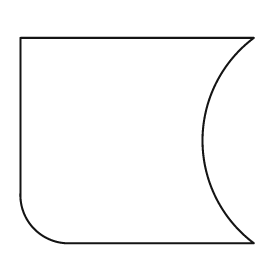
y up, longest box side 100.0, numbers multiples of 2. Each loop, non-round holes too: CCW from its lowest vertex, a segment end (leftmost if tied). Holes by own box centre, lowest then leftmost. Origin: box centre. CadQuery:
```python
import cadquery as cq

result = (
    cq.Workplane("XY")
    .moveTo(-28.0, -44.0)
    .lineTo(50.0, -44.0)
    .threePointArc((28.0, 0.0), (50.0, 44.0))
    .lineTo(-50.0, 44.0)
    .lineTo(-50.0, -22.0)
    .threePointArc((-44.0, -38.0), (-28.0, -44.0))
    .close()
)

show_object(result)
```